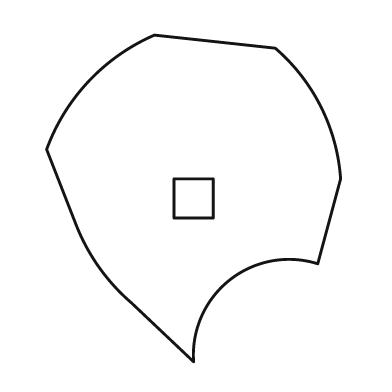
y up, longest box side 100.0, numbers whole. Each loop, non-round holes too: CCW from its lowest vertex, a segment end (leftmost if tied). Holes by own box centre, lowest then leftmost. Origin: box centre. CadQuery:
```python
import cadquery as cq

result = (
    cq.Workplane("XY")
    .moveTo(0.0, -50.0)
    .threePointArc((11.0, -25.0), (38.0, -20.0))
    .lineTo(45.0, 6.0)
    .threePointArc((39.0, 28.0), (25.0, 46.0))
    .lineTo(-12.0, 50.0)
    .threePointArc((-32.0, 36.0), (-45.0, 15.0))
    .lineTo(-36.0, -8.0)
    .threePointArc((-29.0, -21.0), (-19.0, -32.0))
    .close()
    .moveTo(-6.0, -6.0)
    .lineTo(6.0, -6.0)
    .lineTo(6.0, 6.0)
    .lineTo(-6.0, 6.0)
    .close()
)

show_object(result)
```